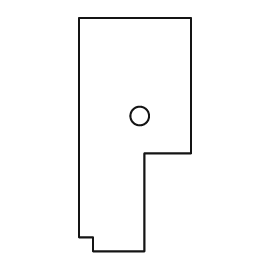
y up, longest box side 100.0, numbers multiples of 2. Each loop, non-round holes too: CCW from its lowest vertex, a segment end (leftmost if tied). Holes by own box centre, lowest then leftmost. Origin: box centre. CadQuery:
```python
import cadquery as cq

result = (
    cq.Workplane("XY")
    .moveTo(-18.0, -50.0)
    .lineTo(4.0, -50.0)
    .lineTo(4.0, -8.0)
    .lineTo(24.0, -8.0)
    .lineTo(24.0, 50.0)
    .lineTo(-24.0, 50.0)
    .lineTo(-24.0, -44.0)
    .lineTo(-18.0, -44.0)
    .close()
    .moveTo(2.0, 8.0)
    .circle(4.0)
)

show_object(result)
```